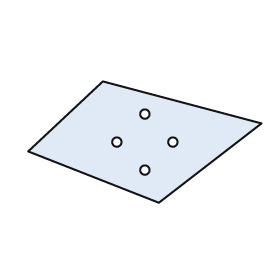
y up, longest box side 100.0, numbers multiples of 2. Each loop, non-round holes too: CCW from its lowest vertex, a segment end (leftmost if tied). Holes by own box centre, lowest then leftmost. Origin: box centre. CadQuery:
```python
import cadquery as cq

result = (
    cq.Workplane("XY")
    .moveTo(6.0, -26.0)
    .lineTo(50.0, 8.0)
    .lineTo(-18.0, 26.0)
    .lineTo(-50.0, -4.0)
    .close()
    .moveTo(0.0, -12.0)
    .circle(2.0)
    .moveTo(-12.0, 0.0)
    .circle(2.0)
    .moveTo(12.0, 0.0)
    .circle(2.0)
    .moveTo(0.0, 12.0)
    .circle(2.0)
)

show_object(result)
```